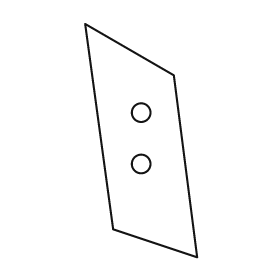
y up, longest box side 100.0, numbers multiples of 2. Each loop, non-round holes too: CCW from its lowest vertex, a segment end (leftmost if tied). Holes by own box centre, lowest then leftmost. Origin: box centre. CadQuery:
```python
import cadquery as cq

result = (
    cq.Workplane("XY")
    .moveTo(24.0, -50.0)
    .lineTo(14.0, 28.0)
    .lineTo(-24.0, 50.0)
    .lineTo(-12.0, -38.0)
    .close()
    .moveTo(0.0, -10.0)
    .circle(4.0)
    .moveTo(0.0, 12.0)
    .circle(4.0)
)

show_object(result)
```